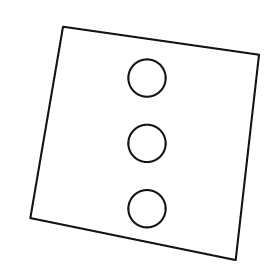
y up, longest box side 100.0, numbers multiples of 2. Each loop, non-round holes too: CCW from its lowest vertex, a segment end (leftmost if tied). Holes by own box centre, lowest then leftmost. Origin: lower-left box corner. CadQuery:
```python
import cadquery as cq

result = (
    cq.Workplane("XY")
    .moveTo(88.0, 0.0)
    .lineTo(98.0, 88.0)
    .lineTo(14.0, 100.0)
    .lineTo(0.0, 18.0)
    .close()
    .moveTo(50.0, 22.0)
    .circle(8.0)
    .moveTo(50.0, 50.0)
    .circle(8.0)
    .moveTo(50.0, 78.0)
    .circle(8.0)
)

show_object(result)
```